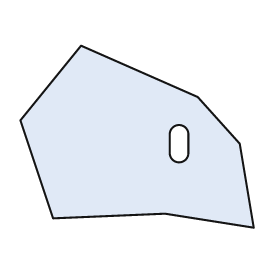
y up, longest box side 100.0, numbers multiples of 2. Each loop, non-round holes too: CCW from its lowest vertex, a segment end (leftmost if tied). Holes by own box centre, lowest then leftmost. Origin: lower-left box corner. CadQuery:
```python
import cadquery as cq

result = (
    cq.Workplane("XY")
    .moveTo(100.0, 0.0)
    .lineTo(94.0, 36.0)
    .lineTo(76.0, 56.0)
    .lineTo(26.0, 78.0)
    .lineTo(0.0, 46.0)
    .lineTo(14.0, 4.0)
    .lineTo(62.0, 6.0)
    .close()
    .moveTo(64.0, 32.0)
    .threePointArc((68.0, 28.0), (72.0, 32.0))
    .lineTo(72.0, 40.0)
    .threePointArc((68.0, 44.0), (64.0, 40.0))
    .close()
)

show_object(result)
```